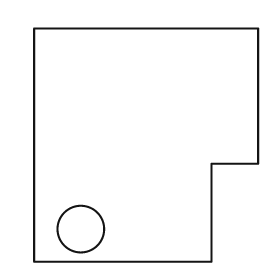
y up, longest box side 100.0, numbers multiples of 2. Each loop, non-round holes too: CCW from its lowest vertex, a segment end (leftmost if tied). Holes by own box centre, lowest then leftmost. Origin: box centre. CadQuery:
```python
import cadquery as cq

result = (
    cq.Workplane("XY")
    .moveTo(-48.0, -50.0)
    .lineTo(28.0, -50.0)
    .lineTo(28.0, -8.0)
    .lineTo(48.0, -8.0)
    .lineTo(48.0, 50.0)
    .lineTo(-48.0, 50.0)
    .close()
    .moveTo(-28.0, -36.0)
    .circle(10.0)
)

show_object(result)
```